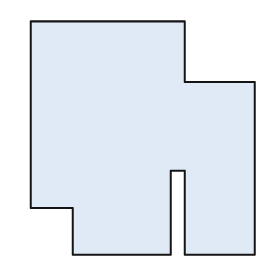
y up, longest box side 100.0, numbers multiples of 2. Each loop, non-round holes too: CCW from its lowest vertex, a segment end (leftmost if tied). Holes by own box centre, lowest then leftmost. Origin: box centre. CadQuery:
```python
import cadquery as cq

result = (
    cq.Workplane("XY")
    .moveTo(-30.0, -50.0)
    .lineTo(12.0, -50.0)
    .lineTo(12.0, -14.0)
    .lineTo(18.0, -14.0)
    .lineTo(18.0, -50.0)
    .lineTo(48.0, -50.0)
    .lineTo(48.0, 24.0)
    .lineTo(18.0, 24.0)
    .lineTo(18.0, 50.0)
    .lineTo(-48.0, 50.0)
    .lineTo(-48.0, -30.0)
    .lineTo(-30.0, -30.0)
    .close()
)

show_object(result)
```